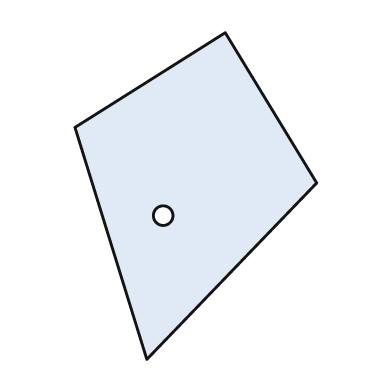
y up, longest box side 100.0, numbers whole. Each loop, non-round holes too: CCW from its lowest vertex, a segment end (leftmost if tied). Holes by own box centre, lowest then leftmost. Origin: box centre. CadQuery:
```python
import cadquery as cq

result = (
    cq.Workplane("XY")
    .moveTo(-15.0, -50.0)
    .lineTo(37.0, 4.0)
    .lineTo(9.0, 50.0)
    .lineTo(-37.0, 21.0)
    .close()
    .moveTo(-10.0, -6.0)
    .circle(3.0)
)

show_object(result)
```